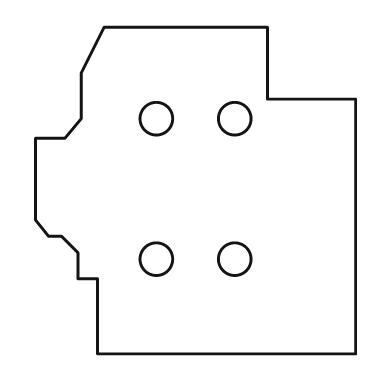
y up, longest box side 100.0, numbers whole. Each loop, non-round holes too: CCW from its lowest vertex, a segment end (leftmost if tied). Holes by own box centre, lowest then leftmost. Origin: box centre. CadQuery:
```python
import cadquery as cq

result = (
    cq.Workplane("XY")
    .moveTo(-30.0, -50.0)
    .lineTo(49.0, -50.0)
    .lineTo(49.0, 28.0)
    .lineTo(22.0, 28.0)
    .lineTo(22.0, 50.0)
    .lineTo(-28.0, 50.0)
    .lineTo(-35.0, 36.0)
    .lineTo(-35.0, 22.0)
    .lineTo(-40.0, 16.0)
    .lineTo(-49.0, 16.0)
    .lineTo(-49.0, -9.0)
    .lineTo(-45.0, -14.0)
    .lineTo(-41.0, -14.0)
    .lineTo(-36.0, -19.0)
    .lineTo(-36.0, -27.0)
    .lineTo(-30.0, -27.0)
    .close()
    .moveTo(-12.0, -21.0)
    .circle(5.0)
    .moveTo(12.0, -21.0)
    .circle(5.0)
    .moveTo(-12.0, 22.0)
    .circle(5.0)
    .moveTo(12.0, 22.0)
    .circle(5.0)
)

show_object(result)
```